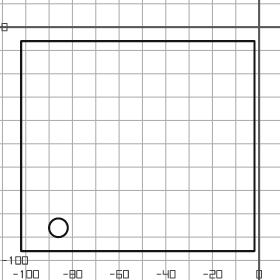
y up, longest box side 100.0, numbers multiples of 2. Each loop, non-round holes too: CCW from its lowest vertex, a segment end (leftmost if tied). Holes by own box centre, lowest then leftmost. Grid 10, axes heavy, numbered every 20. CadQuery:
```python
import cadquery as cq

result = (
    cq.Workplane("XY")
    .moveTo(-102.0, -96.0)
    .lineTo(-2.0, -96.0)
    .lineTo(-2.0, -6.0)
    .lineTo(-102.0, -6.0)
    .close()
    .moveTo(-86.0, -86.0)
    .circle(4.0)
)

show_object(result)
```